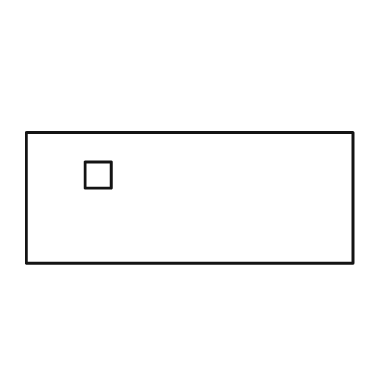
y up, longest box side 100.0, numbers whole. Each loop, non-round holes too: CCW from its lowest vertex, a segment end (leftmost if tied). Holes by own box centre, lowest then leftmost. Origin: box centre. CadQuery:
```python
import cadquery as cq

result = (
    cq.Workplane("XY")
    .moveTo(-50.0, -20.0)
    .lineTo(50.0, -20.0)
    .lineTo(50.0, 20.0)
    .lineTo(-50.0, 20.0)
    .close()
    .moveTo(-32.0, 3.0)
    .lineTo(-24.0, 3.0)
    .lineTo(-24.0, 11.0)
    .lineTo(-32.0, 11.0)
    .close()
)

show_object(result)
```